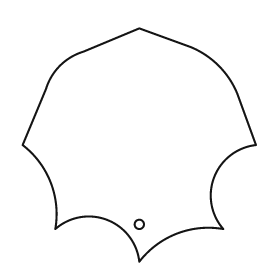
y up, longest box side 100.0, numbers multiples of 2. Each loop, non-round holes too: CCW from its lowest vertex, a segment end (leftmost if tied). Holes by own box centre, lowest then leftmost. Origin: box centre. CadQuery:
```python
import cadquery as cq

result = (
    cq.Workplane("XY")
    .moveTo(0.0, -50.0)
    .threePointArc((16.0, -38.0), (36.0, -36.0))
    .threePointArc((32.0, -14.0), (50.0, 0.0))
    .lineTo(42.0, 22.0)
    .threePointArc((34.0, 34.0), (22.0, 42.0))
    .lineTo(0.0, 50.0)
    .lineTo(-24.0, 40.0)
    .threePointArc((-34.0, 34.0), (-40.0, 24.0))
    .lineTo(-50.0, 0.0)
    .threePointArc((-38.0, -16.0), (-36.0, -36.0))
    .threePointArc((-14.0, -32.0), (0.0, -50.0))
    .close()
    .moveTo(0.0, -34.0)
    .circle(2.0)
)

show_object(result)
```